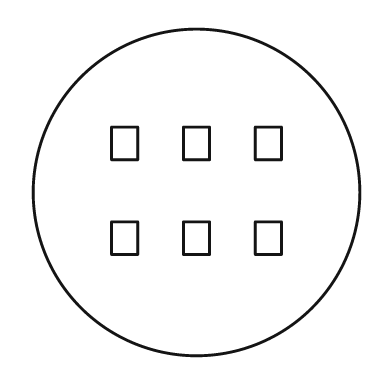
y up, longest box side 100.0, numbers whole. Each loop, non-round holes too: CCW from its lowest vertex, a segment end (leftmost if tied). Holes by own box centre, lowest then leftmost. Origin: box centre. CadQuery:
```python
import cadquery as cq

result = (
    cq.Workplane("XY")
    .moveTo(0.0, 0.0)
    .circle(50.0)
    .moveTo(-26.0, -19.0)
    .lineTo(-18.0, -19.0)
    .lineTo(-18.0, -9.0)
    .lineTo(-26.0, -9.0)
    .close()
    .moveTo(-4.0, -19.0)
    .lineTo(4.0, -19.0)
    .lineTo(4.0, -9.0)
    .lineTo(-4.0, -9.0)
    .close()
    .moveTo(18.0, -19.0)
    .lineTo(26.0, -19.0)
    .lineTo(26.0, -9.0)
    .lineTo(18.0, -9.0)
    .close()
    .moveTo(-26.0, 10.0)
    .lineTo(-18.0, 10.0)
    .lineTo(-18.0, 20.0)
    .lineTo(-26.0, 20.0)
    .close()
    .moveTo(-4.0, 10.0)
    .lineTo(4.0, 10.0)
    .lineTo(4.0, 20.0)
    .lineTo(-4.0, 20.0)
    .close()
    .moveTo(18.0, 10.0)
    .lineTo(26.0, 10.0)
    .lineTo(26.0, 20.0)
    .lineTo(18.0, 20.0)
    .close()
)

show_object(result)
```